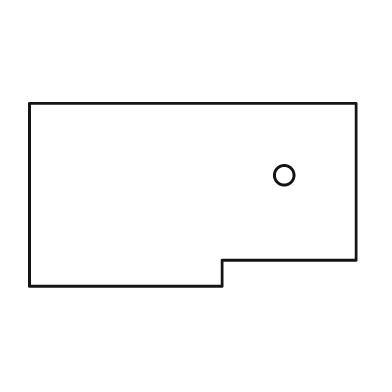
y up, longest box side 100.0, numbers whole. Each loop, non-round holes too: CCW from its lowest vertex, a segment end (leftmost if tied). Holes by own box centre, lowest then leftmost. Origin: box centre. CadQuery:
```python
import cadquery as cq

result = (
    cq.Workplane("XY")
    .moveTo(-50.0, -28.0)
    .lineTo(9.0, -28.0)
    .lineTo(9.0, -20.0)
    .lineTo(50.0, -20.0)
    .lineTo(50.0, 28.0)
    .lineTo(-50.0, 28.0)
    .close()
    .moveTo(28.0, 6.0)
    .circle(3.0)
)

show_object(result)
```